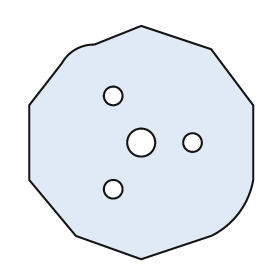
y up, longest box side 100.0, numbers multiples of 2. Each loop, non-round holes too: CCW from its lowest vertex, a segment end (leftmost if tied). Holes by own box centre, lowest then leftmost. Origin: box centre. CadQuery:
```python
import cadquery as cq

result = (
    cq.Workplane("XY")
    .moveTo(0.0, -50.0)
    .lineTo(30.0, -40.0)
    .threePointArc((42.0, -30.0), (48.0, -16.0))
    .lineTo(48.0, 16.0)
    .lineTo(30.0, 40.0)
    .lineTo(0.0, 50.0)
    .lineTo(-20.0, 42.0)
    .threePointArc((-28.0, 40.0), (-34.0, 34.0))
    .lineTo(-48.0, 16.0)
    .lineTo(-48.0, -16.0)
    .lineTo(-28.0, -40.0)
    .close()
    .moveTo(-12.0, -20.0)
    .circle(4.0)
    .moveTo(0.0, 0.0)
    .circle(6.0)
    .moveTo(22.0, 0.0)
    .circle(4.0)
    .moveTo(-12.0, 20.0)
    .circle(4.0)
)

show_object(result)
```